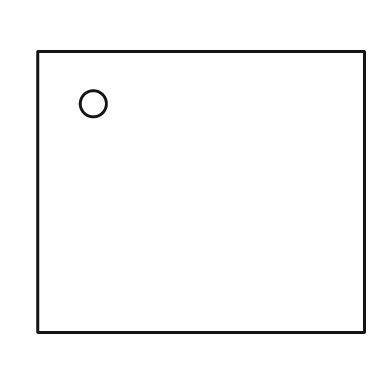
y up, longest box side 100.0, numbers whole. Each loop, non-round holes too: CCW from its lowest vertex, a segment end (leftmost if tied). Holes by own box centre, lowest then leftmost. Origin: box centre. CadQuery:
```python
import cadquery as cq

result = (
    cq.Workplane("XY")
    .moveTo(-50.0, -43.0)
    .lineTo(50.0, -43.0)
    .lineTo(50.0, 43.0)
    .lineTo(-50.0, 43.0)
    .close()
    .moveTo(-33.0, 27.0)
    .circle(4.0)
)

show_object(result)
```